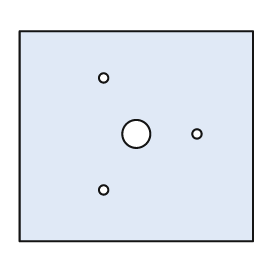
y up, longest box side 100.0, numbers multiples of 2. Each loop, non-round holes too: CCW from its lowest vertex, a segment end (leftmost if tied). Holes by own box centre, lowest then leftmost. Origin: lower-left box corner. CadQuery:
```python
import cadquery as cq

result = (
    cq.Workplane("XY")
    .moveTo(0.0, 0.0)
    .lineTo(100.0, 0.0)
    .lineTo(100.0, 90.0)
    .lineTo(0.0, 90.0)
    .close()
    .moveTo(36.0, 22.0)
    .circle(2.0)
    .moveTo(50.0, 46.0)
    .circle(6.0)
    .moveTo(76.0, 46.0)
    .circle(2.0)
    .moveTo(36.0, 70.0)
    .circle(2.0)
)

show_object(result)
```